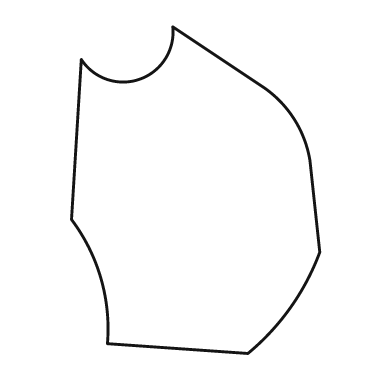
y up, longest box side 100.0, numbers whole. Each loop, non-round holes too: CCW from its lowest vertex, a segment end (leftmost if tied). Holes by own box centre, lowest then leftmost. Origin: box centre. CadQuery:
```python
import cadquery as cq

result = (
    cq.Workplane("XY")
    .moveTo(16.0, -50.0)
    .threePointArc((29.0, -36.0), (38.0, -19.0))
    .lineTo(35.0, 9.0)
    .threePointArc((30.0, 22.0), (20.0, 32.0))
    .lineTo(-7.0, 50.0)
    .threePointArc((-17.0, 34.0), (-35.0, 40.0))
    .lineTo(-38.0, -9.0)
    .threePointArc((-29.0, -27.0), (-27.0, -47.0))
    .close()
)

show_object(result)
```